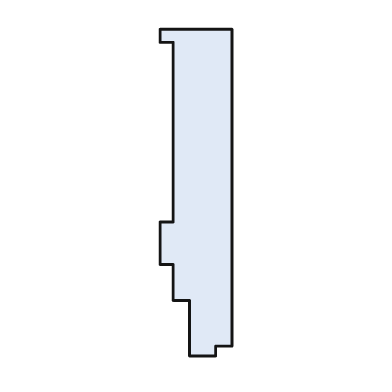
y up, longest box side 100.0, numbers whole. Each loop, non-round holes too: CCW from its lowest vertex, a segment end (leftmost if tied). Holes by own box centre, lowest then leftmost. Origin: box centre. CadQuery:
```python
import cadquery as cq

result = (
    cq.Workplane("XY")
    .moveTo(-2.0, -50.0)
    .lineTo(6.0, -50.0)
    .lineTo(6.0, -47.0)
    .lineTo(11.0, -47.0)
    .lineTo(11.0, 50.0)
    .lineTo(-11.0, 50.0)
    .lineTo(-11.0, 46.0)
    .lineTo(-7.0, 46.0)
    .lineTo(-7.0, -9.0)
    .lineTo(-11.0, -9.0)
    .lineTo(-11.0, -22.0)
    .lineTo(-7.0, -22.0)
    .lineTo(-7.0, -33.0)
    .lineTo(-2.0, -33.0)
    .close()
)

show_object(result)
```